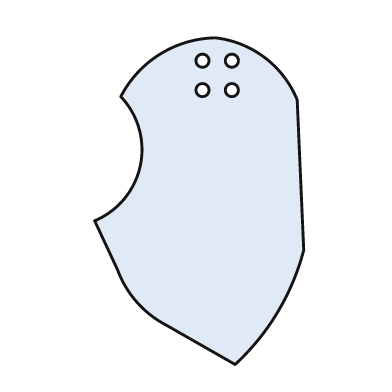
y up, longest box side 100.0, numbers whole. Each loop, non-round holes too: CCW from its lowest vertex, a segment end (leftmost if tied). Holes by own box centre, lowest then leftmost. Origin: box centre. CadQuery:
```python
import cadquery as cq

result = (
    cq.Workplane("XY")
    .moveTo(11.0, -50.0)
    .threePointArc((24.0, -34.0), (32.0, -15.0))
    .lineTo(30.0, 31.0)
    .threePointArc((20.0, 44.0), (5.0, 50.0))
    .threePointArc((-12.0, 45.0), (-24.0, 32.0))
    .threePointArc((-18.0, 11.0), (-32.0, -6.0))
    .lineTo(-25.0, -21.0)
    .threePointArc((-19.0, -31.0), (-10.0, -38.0))
    .close()
    .moveTo(1.0, 34.0)
    .circle(2.0)
    .moveTo(10.0, 34.0)
    .circle(2.0)
    .moveTo(1.0, 43.0)
    .circle(2.0)
    .moveTo(10.0, 43.0)
    .circle(2.0)
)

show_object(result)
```